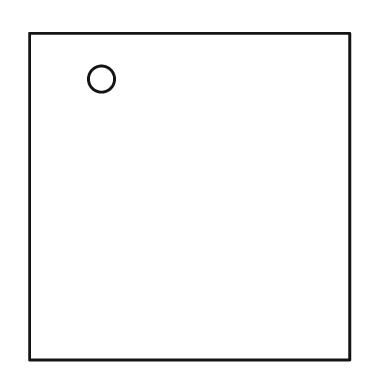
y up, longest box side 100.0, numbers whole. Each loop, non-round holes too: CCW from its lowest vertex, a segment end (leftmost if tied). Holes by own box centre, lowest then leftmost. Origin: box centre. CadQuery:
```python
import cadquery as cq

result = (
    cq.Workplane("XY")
    .moveTo(-49.0, -50.0)
    .lineTo(49.0, -50.0)
    .lineTo(49.0, 50.0)
    .lineTo(-49.0, 50.0)
    .close()
    .moveTo(-27.0, 36.0)
    .circle(4.0)
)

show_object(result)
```